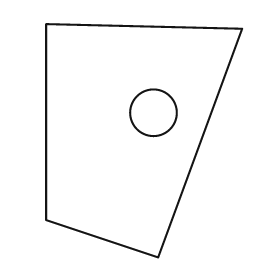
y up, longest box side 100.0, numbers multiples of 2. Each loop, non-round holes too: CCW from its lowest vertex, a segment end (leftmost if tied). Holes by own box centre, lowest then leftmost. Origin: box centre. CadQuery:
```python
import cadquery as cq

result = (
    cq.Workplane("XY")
    .moveTo(6.0, -50.0)
    .lineTo(42.0, 48.0)
    .lineTo(-42.0, 50.0)
    .lineTo(-42.0, -34.0)
    .close()
    .moveTo(4.0, 12.0)
    .circle(10.0)
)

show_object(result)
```